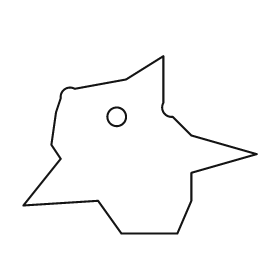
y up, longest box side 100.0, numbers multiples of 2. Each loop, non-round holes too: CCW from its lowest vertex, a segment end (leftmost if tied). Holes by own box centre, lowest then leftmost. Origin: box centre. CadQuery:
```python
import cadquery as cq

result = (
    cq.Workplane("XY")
    .moveTo(-8.0, -38.0)
    .lineTo(16.0, -38.0)
    .lineTo(22.0, -24.0)
    .lineTo(22.0, -12.0)
    .lineTo(50.0, -4.0)
    .lineTo(22.0, 4.0)
    .lineTo(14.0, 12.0)
    .threePointArc((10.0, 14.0), (10.0, 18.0))
    .lineTo(10.0, 38.0)
    .lineTo(-6.0, 28.0)
    .lineTo(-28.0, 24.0)
    .threePointArc((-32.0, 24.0), (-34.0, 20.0))
    .lineTo(-36.0, 14.0)
    .lineTo(-38.0, 0.0)
    .lineTo(-34.0, -6.0)
    .lineTo(-50.0, -26.0)
    .lineTo(-18.0, -24.0)
    .close()
    .moveTo(-10.0, 12.0)
    .circle(4.0)
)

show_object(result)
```